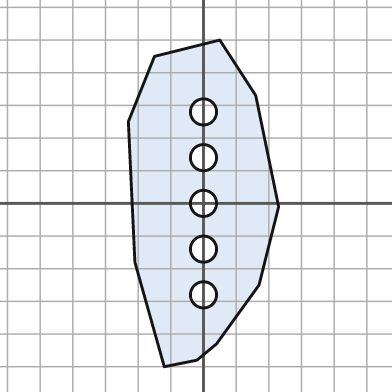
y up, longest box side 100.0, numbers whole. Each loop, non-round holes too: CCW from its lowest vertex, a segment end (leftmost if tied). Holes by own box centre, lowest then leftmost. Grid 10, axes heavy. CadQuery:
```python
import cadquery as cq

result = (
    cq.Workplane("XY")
    .moveTo(-12.0, -50.0)
    .lineTo(-2.0, -48.0)
    .lineTo(4.0, -43.0)
    .lineTo(17.0, -25.0)
    .lineTo(23.0, -1.0)
    .lineTo(16.0, 33.0)
    .lineTo(5.0, 50.0)
    .lineTo(-15.0, 45.0)
    .lineTo(-23.0, 25.0)
    .lineTo(-21.0, -18.0)
    .close()
    .moveTo(0.0, -28.0)
    .circle(4.0)
    .moveTo(0.0, -14.0)
    .circle(4.0)
    .moveTo(0.0, 0.0)
    .circle(4.0)
    .moveTo(0.0, 14.0)
    .circle(4.0)
    .moveTo(0.0, 28.0)
    .circle(4.0)
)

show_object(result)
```